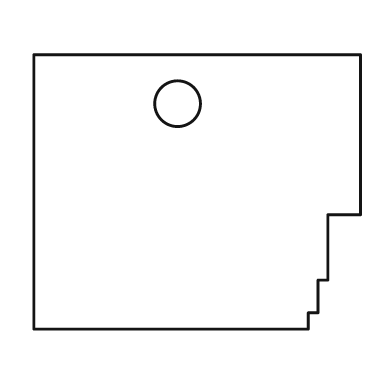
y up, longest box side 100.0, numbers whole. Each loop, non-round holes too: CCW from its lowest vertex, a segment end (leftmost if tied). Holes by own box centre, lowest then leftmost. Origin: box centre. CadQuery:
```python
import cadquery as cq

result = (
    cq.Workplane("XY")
    .moveTo(-50.0, -42.0)
    .lineTo(34.0, -42.0)
    .lineTo(34.0, -37.0)
    .lineTo(37.0, -37.0)
    .lineTo(37.0, -27.0)
    .lineTo(40.0, -27.0)
    .lineTo(40.0, -7.0)
    .lineTo(50.0, -7.0)
    .lineTo(50.0, 42.0)
    .lineTo(-50.0, 42.0)
    .close()
    .moveTo(-6.0, 27.0)
    .circle(7.0)
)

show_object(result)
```